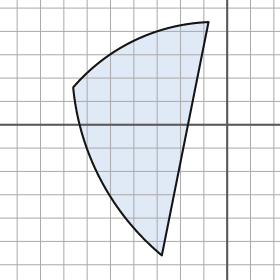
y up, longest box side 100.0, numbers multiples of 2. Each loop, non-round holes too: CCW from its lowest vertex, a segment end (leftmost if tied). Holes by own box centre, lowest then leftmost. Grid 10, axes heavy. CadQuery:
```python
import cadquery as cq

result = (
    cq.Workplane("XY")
    .moveTo(-28.0, -56.0)
    .lineTo(-8.0, 44.0)
    .threePointArc((-40.0, 36.0), (-66.0, 16.0))
    .threePointArc((-54.0, -24.0), (-28.0, -56.0))
    .close()
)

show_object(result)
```